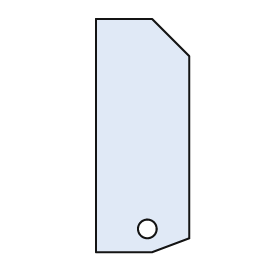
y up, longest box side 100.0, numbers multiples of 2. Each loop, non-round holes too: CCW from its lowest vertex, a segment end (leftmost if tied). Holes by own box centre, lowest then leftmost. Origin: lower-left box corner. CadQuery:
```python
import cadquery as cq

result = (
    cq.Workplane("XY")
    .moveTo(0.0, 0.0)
    .lineTo(24.0, 0.0)
    .lineTo(40.0, 6.0)
    .lineTo(40.0, 84.0)
    .lineTo(24.0, 100.0)
    .lineTo(0.0, 100.0)
    .close()
    .moveTo(22.0, 10.0)
    .circle(4.0)
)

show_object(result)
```